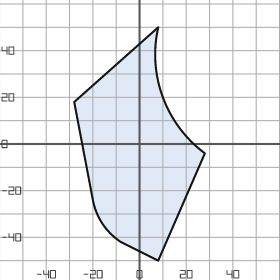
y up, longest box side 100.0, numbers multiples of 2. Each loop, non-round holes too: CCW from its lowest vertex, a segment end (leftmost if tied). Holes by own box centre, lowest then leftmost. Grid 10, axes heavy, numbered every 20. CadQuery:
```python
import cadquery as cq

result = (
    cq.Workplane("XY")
    .moveTo(8.0, -50.0)
    .lineTo(28.0, -4.0)
    .threePointArc((10.0, 20.0), (8.0, 50.0))
    .lineTo(-28.0, 18.0)
    .lineTo(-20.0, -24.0)
    .threePointArc((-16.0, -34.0), (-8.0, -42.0))
    .close()
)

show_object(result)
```